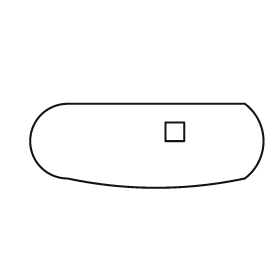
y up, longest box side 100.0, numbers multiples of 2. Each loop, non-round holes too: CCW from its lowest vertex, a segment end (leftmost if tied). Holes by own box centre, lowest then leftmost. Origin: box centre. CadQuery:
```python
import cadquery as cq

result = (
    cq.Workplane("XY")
    .moveTo(-34.0, -14.0)
    .threePointArc((4.0, -18.0), (42.0, -14.0))
    .threePointArc((50.0, 2.0), (42.0, 18.0))
    .lineTo(-34.0, 18.0)
    .threePointArc((-50.0, 2.0), (-34.0, -14.0))
    .close()
    .moveTo(8.0, 2.0)
    .lineTo(16.0, 2.0)
    .lineTo(16.0, 10.0)
    .lineTo(8.0, 10.0)
    .close()
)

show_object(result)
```